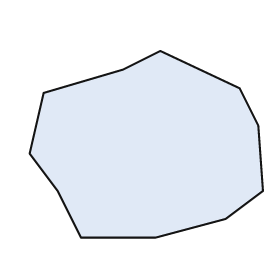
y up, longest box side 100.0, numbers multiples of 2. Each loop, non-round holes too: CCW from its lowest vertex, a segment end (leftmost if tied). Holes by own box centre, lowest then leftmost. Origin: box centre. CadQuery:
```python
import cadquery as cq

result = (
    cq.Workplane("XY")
    .moveTo(-28.0, -40.0)
    .lineTo(4.0, -40.0)
    .lineTo(34.0, -32.0)
    .lineTo(50.0, -20.0)
    .lineTo(48.0, 8.0)
    .lineTo(40.0, 24.0)
    .lineTo(6.0, 40.0)
    .lineTo(-10.0, 32.0)
    .lineTo(-44.0, 22.0)
    .lineTo(-50.0, -4.0)
    .lineTo(-38.0, -20.0)
    .close()
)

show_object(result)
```